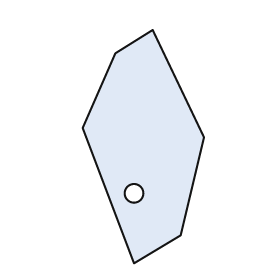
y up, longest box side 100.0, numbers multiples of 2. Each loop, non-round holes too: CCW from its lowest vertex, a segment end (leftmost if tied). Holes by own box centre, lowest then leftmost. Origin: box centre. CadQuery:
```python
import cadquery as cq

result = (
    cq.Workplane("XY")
    .moveTo(-4.0, -50.0)
    .lineTo(16.0, -38.0)
    .lineTo(26.0, 4.0)
    .lineTo(4.0, 50.0)
    .lineTo(-12.0, 40.0)
    .lineTo(-26.0, 8.0)
    .close()
    .moveTo(-4.0, -20.0)
    .circle(4.0)
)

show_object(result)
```